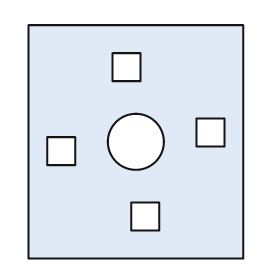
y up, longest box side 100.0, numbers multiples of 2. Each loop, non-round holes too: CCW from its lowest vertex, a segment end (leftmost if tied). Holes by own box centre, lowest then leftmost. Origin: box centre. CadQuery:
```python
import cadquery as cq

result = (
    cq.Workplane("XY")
    .moveTo(-46.0, -50.0)
    .lineTo(46.0, -50.0)
    .lineTo(46.0, 50.0)
    .lineTo(-46.0, 50.0)
    .close()
    .moveTo(-2.0, -38.0)
    .lineTo(10.0, -38.0)
    .lineTo(10.0, -26.0)
    .lineTo(-2.0, -26.0)
    .close()
    .moveTo(-38.0, -10.0)
    .lineTo(-26.0, -10.0)
    .lineTo(-26.0, 2.0)
    .lineTo(-38.0, 2.0)
    .close()
    .moveTo(0.0, 0.0)
    .circle(12.0)
    .moveTo(26.0, -2.0)
    .lineTo(38.0, -2.0)
    .lineTo(38.0, 10.0)
    .lineTo(26.0, 10.0)
    .close()
    .moveTo(-10.0, 26.0)
    .lineTo(2.0, 26.0)
    .lineTo(2.0, 38.0)
    .lineTo(-10.0, 38.0)
    .close()
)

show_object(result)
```